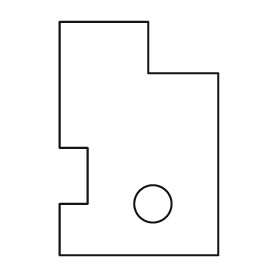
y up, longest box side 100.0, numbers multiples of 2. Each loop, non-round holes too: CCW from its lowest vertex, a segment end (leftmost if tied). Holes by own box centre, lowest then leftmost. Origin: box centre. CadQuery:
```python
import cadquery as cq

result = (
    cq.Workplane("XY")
    .moveTo(-34.0, -50.0)
    .lineTo(34.0, -50.0)
    .lineTo(34.0, 28.0)
    .lineTo(4.0, 28.0)
    .lineTo(4.0, 50.0)
    .lineTo(-34.0, 50.0)
    .lineTo(-34.0, -4.0)
    .lineTo(-22.0, -4.0)
    .lineTo(-22.0, -28.0)
    .lineTo(-34.0, -28.0)
    .close()
    .moveTo(6.0, -28.0)
    .circle(8.0)
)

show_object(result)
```